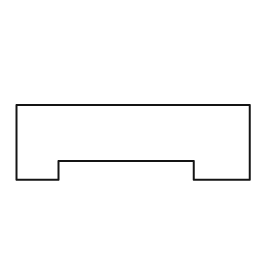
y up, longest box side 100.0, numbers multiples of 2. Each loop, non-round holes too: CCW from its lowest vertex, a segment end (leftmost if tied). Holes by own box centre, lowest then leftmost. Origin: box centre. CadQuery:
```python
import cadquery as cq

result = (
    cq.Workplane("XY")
    .moveTo(-50.0, -16.0)
    .lineTo(-32.0, -16.0)
    .lineTo(-32.0, -8.0)
    .lineTo(26.0, -8.0)
    .lineTo(26.0, -16.0)
    .lineTo(50.0, -16.0)
    .lineTo(50.0, 16.0)
    .lineTo(-50.0, 16.0)
    .close()
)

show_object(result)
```